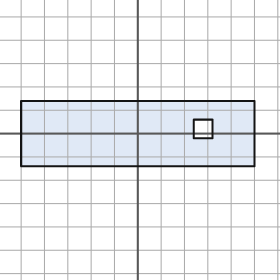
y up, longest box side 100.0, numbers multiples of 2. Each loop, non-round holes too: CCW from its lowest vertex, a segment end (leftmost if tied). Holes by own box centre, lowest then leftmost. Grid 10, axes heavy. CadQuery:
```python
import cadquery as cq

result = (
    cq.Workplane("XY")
    .moveTo(-50.0, -14.0)
    .lineTo(50.0, -14.0)
    .lineTo(50.0, 14.0)
    .lineTo(-50.0, 14.0)
    .close()
    .moveTo(24.0, -2.0)
    .lineTo(32.0, -2.0)
    .lineTo(32.0, 6.0)
    .lineTo(24.0, 6.0)
    .close()
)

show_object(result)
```